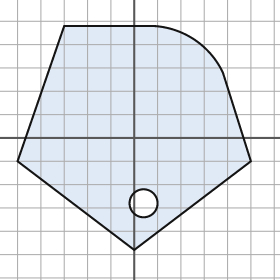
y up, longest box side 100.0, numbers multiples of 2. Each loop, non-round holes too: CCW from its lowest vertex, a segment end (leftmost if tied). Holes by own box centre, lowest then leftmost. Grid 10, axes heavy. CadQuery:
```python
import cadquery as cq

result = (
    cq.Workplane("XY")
    .moveTo(0.0, -48.0)
    .lineTo(50.0, -10.0)
    .lineTo(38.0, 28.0)
    .threePointArc((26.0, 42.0), (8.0, 48.0))
    .lineTo(-30.0, 48.0)
    .lineTo(-50.0, -10.0)
    .close()
    .moveTo(4.0, -28.0)
    .circle(6.0)
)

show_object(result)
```